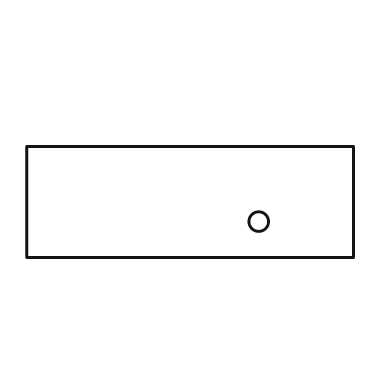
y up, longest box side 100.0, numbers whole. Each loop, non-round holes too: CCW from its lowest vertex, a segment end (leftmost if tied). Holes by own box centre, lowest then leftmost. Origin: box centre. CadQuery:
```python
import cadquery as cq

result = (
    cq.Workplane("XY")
    .moveTo(-50.0, -17.0)
    .lineTo(50.0, -17.0)
    .lineTo(50.0, 17.0)
    .lineTo(-50.0, 17.0)
    .close()
    .moveTo(21.0, -6.0)
    .circle(3.0)
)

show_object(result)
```